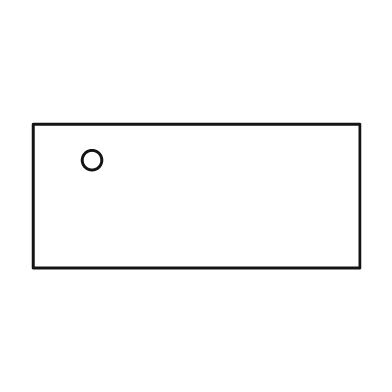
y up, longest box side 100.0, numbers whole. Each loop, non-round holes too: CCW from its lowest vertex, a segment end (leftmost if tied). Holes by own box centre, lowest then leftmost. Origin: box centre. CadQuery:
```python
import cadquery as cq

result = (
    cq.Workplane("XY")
    .moveTo(-50.0, -22.0)
    .lineTo(50.0, -22.0)
    .lineTo(50.0, 22.0)
    .lineTo(-50.0, 22.0)
    .close()
    .moveTo(-32.0, 11.0)
    .circle(3.0)
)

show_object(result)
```